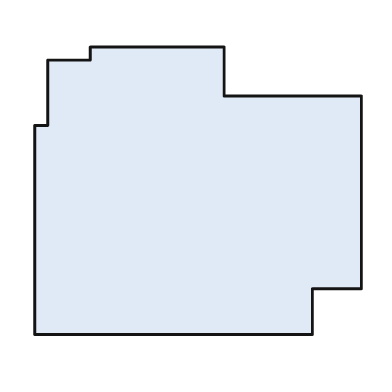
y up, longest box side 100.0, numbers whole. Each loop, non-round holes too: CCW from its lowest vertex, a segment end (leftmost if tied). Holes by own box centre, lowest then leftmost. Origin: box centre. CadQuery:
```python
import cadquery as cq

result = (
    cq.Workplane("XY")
    .moveTo(-50.0, -44.0)
    .lineTo(35.0, -44.0)
    .lineTo(35.0, -30.0)
    .lineTo(50.0, -30.0)
    .lineTo(50.0, 29.0)
    .lineTo(8.0, 29.0)
    .lineTo(8.0, 44.0)
    .lineTo(-33.0, 44.0)
    .lineTo(-33.0, 40.0)
    .lineTo(-46.0, 40.0)
    .lineTo(-46.0, 20.0)
    .lineTo(-50.0, 20.0)
    .close()
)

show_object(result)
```